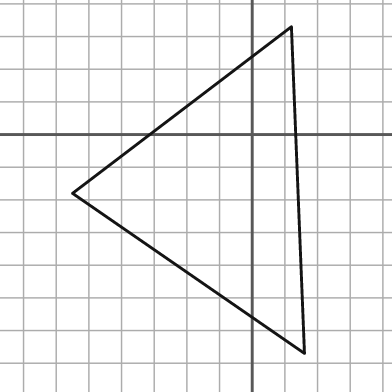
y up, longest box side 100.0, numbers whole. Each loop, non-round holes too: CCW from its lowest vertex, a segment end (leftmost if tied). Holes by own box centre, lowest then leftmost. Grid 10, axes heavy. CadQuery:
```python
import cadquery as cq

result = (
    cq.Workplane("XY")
    .moveTo(16.0, -67.0)
    .lineTo(12.0, 33.0)
    .lineTo(-55.0, -18.0)
    .close()
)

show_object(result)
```